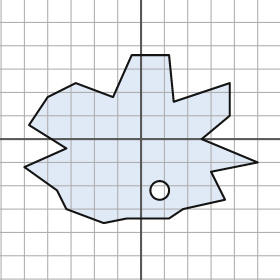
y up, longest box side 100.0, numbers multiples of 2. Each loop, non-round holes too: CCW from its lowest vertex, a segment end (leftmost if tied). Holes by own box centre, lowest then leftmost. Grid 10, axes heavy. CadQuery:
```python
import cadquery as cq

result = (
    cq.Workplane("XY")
    .moveTo(-16.0, -36.0)
    .lineTo(-6.0, -34.0)
    .lineTo(12.0, -34.0)
    .lineTo(18.0, -30.0)
    .lineTo(36.0, -26.0)
    .lineTo(30.0, -14.0)
    .lineTo(50.0, -10.0)
    .lineTo(26.0, 0.0)
    .lineTo(38.0, 10.0)
    .lineTo(38.0, 24.0)
    .lineTo(14.0, 16.0)
    .lineTo(12.0, 36.0)
    .lineTo(-4.0, 36.0)
    .lineTo(-12.0, 18.0)
    .lineTo(-28.0, 24.0)
    .lineTo(-40.0, 18.0)
    .lineTo(-48.0, 6.0)
    .lineTo(-32.0, -4.0)
    .lineTo(-50.0, -12.0)
    .lineTo(-36.0, -22.0)
    .lineTo(-32.0, -30.0)
    .close()
    .moveTo(8.0, -22.0)
    .circle(4.0)
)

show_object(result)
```